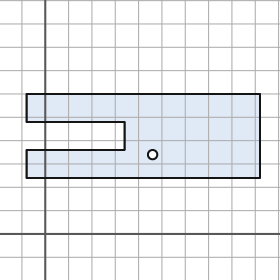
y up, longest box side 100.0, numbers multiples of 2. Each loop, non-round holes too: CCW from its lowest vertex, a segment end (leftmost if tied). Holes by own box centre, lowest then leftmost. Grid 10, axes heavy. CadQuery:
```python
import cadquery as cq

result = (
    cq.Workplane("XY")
    .moveTo(-8.0, 24.0)
    .lineTo(92.0, 24.0)
    .lineTo(92.0, 60.0)
    .lineTo(-8.0, 60.0)
    .lineTo(-8.0, 48.0)
    .lineTo(34.0, 48.0)
    .lineTo(34.0, 36.0)
    .lineTo(-8.0, 36.0)
    .close()
    .moveTo(46.0, 34.0)
    .circle(2.0)
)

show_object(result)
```